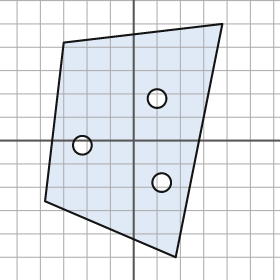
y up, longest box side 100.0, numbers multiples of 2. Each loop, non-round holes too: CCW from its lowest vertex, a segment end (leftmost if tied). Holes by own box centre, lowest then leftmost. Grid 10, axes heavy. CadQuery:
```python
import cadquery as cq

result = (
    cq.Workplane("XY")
    .moveTo(18.0, -50.0)
    .lineTo(38.0, 50.0)
    .lineTo(-30.0, 42.0)
    .lineTo(-38.0, -26.0)
    .close()
    .moveTo(12.0, -18.0)
    .circle(4.0)
    .moveTo(-22.0, -2.0)
    .circle(4.0)
    .moveTo(10.0, 18.0)
    .circle(4.0)
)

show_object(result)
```